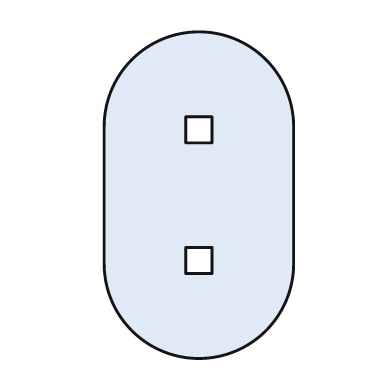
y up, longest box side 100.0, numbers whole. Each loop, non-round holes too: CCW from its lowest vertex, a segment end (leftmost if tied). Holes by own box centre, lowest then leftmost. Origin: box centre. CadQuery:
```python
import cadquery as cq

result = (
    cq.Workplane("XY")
    .moveTo(-29.0, -21.0)
    .threePointArc((0.0, -50.0), (29.0, -21.0))
    .lineTo(29.0, 21.0)
    .threePointArc((0.0, 50.0), (-29.0, 21.0))
    .close()
    .moveTo(-4.0, -24.0)
    .lineTo(4.0, -24.0)
    .lineTo(4.0, -16.0)
    .lineTo(-4.0, -16.0)
    .close()
    .moveTo(-4.0, 16.0)
    .lineTo(4.0, 16.0)
    .lineTo(4.0, 24.0)
    .lineTo(-4.0, 24.0)
    .close()
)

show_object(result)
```